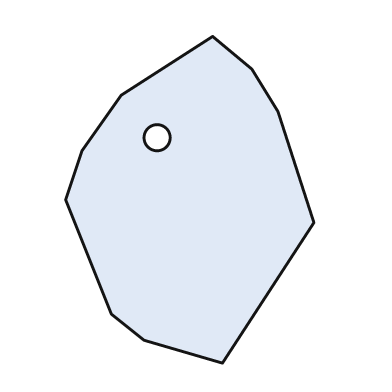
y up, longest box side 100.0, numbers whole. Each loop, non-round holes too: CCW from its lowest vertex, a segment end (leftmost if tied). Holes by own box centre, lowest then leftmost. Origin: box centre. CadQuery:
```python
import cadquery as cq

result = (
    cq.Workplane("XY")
    .moveTo(10.0, -50.0)
    .lineTo(38.0, -7.0)
    .lineTo(27.0, 27.0)
    .lineTo(19.0, 40.0)
    .lineTo(7.0, 50.0)
    .lineTo(-21.0, 32.0)
    .lineTo(-33.0, 15.0)
    .lineTo(-38.0, 0.0)
    .lineTo(-24.0, -35.0)
    .lineTo(-14.0, -43.0)
    .close()
    .moveTo(-10.0, 19.0)
    .circle(4.0)
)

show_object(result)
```